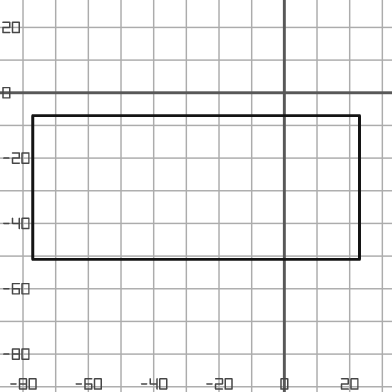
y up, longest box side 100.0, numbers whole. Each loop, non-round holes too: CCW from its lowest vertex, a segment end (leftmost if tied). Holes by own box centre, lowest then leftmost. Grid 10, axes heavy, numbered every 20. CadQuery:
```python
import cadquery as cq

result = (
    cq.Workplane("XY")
    .moveTo(-77.0, -51.0)
    .lineTo(23.0, -51.0)
    .lineTo(23.0, -7.0)
    .lineTo(-77.0, -7.0)
    .close()
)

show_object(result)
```